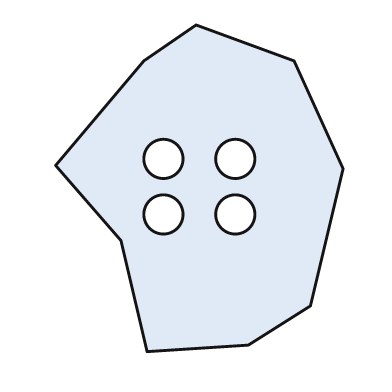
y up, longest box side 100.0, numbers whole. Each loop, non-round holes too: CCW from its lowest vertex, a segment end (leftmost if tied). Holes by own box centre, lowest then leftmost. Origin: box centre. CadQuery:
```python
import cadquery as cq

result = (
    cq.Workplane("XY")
    .moveTo(-16.0, -50.0)
    .lineTo(15.0, -48.0)
    .lineTo(34.0, -36.0)
    .lineTo(44.0, 6.0)
    .lineTo(29.0, 39.0)
    .lineTo(-1.0, 50.0)
    .lineTo(-17.0, 39.0)
    .lineTo(-44.0, 7.0)
    .lineTo(-24.0, -16.0)
    .close()
    .moveTo(-11.0, -8.0)
    .circle(6.0)
    .moveTo(11.0, -8.0)
    .circle(6.0)
    .moveTo(-11.0, 9.0)
    .circle(6.0)
    .moveTo(11.0, 9.0)
    .circle(6.0)
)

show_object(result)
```